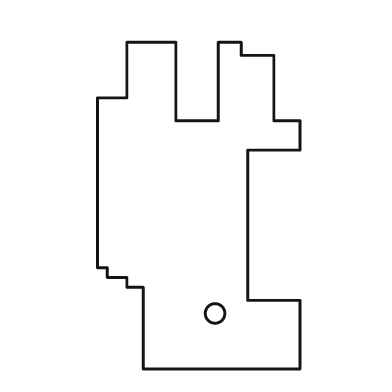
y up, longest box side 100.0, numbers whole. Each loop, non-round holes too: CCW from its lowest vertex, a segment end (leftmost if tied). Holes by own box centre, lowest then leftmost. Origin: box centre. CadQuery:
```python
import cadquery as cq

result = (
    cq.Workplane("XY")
    .moveTo(-17.0, -50.0)
    .lineTo(31.0, -50.0)
    .lineTo(31.0, -29.0)
    .lineTo(15.0, -29.0)
    .lineTo(15.0, 17.0)
    .lineTo(31.0, 17.0)
    .lineTo(31.0, 26.0)
    .lineTo(23.0, 26.0)
    .lineTo(23.0, 46.0)
    .lineTo(13.0, 46.0)
    .lineTo(13.0, 50.0)
    .lineTo(6.0, 50.0)
    .lineTo(6.0, 26.0)
    .lineTo(-7.0, 26.0)
    .lineTo(-7.0, 50.0)
    .lineTo(-22.0, 50.0)
    .lineTo(-22.0, 33.0)
    .lineTo(-31.0, 33.0)
    .lineTo(-31.0, -19.0)
    .lineTo(-28.0, -19.0)
    .lineTo(-28.0, -22.0)
    .lineTo(-22.0, -22.0)
    .lineTo(-22.0, -25.0)
    .lineTo(-17.0, -25.0)
    .close()
    .moveTo(5.0, -33.0)
    .circle(3.0)
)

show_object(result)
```